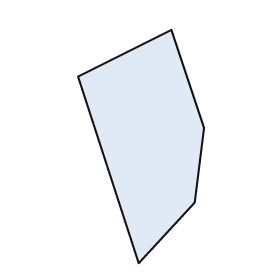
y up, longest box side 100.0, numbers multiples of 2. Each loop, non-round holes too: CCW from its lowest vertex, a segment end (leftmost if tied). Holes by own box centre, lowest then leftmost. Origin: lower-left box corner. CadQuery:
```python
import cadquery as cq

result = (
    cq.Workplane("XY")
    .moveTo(26.0, 0.0)
    .lineTo(50.0, 26.0)
    .lineTo(54.0, 58.0)
    .lineTo(40.0, 100.0)
    .lineTo(0.0, 80.0)
    .close()
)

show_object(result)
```